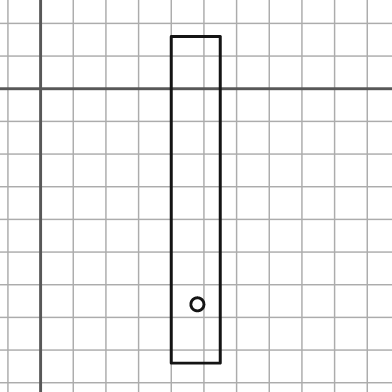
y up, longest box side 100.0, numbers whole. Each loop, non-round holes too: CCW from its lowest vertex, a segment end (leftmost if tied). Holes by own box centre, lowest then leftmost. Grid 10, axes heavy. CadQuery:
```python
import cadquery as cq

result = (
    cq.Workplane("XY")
    .moveTo(40.0, -84.0)
    .lineTo(55.0, -84.0)
    .lineTo(55.0, 16.0)
    .lineTo(40.0, 16.0)
    .close()
    .moveTo(48.0, -66.0)
    .circle(2.0)
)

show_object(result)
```